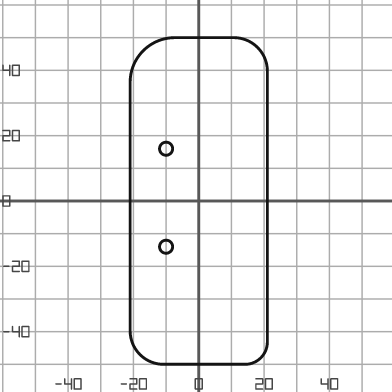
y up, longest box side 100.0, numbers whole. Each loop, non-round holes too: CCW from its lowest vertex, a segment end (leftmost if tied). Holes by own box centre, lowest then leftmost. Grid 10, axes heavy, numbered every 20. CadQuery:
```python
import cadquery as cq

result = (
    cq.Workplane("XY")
    .moveTo(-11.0, -50.0)
    .lineTo(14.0, -50.0)
    .threePointArc((19.0, -48.0), (21.0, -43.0))
    .lineTo(21.0, 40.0)
    .threePointArc((18.0, 47.0), (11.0, 50.0))
    .lineTo(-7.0, 50.0)
    .threePointArc((-17.0, 46.0), (-21.0, 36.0))
    .lineTo(-21.0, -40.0)
    .threePointArc((-18.0, -47.0), (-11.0, -50.0))
    .close()
    .moveTo(-10.0, -14.0)
    .circle(2.0)
    .moveTo(-10.0, 16.0)
    .circle(2.0)
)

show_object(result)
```